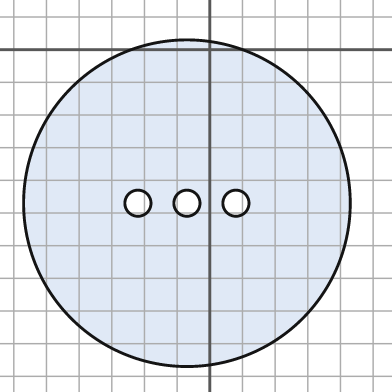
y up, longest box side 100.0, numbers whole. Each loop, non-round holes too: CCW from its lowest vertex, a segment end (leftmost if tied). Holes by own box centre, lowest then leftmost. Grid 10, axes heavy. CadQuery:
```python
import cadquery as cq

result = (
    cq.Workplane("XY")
    .moveTo(-7.0, -47.0)
    .circle(50.0)
    .moveTo(-22.0, -47.0)
    .circle(4.0)
    .moveTo(-7.0, -47.0)
    .circle(4.0)
    .moveTo(8.0, -47.0)
    .circle(4.0)
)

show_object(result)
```